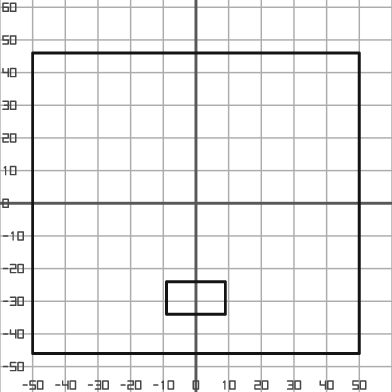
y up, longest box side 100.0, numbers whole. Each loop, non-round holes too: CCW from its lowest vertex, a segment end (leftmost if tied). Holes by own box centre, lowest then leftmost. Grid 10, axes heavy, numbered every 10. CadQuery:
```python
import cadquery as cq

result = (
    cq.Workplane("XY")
    .moveTo(-50.0, -46.0)
    .lineTo(50.0, -46.0)
    .lineTo(50.0, 46.0)
    .lineTo(-50.0, 46.0)
    .close()
    .moveTo(-9.0, -34.0)
    .lineTo(9.0, -34.0)
    .lineTo(9.0, -24.0)
    .lineTo(-9.0, -24.0)
    .close()
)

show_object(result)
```